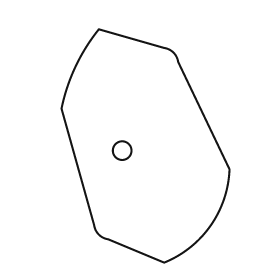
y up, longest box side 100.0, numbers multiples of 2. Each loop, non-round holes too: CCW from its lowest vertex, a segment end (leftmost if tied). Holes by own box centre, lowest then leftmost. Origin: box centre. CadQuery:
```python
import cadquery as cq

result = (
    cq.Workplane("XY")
    .moveTo(8.0, -50.0)
    .threePointArc((28.0, -34.0), (36.0, -10.0))
    .lineTo(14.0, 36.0)
    .threePointArc((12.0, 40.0), (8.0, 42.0))
    .lineTo(-20.0, 50.0)
    .threePointArc((-30.0, 34.0), (-36.0, 16.0))
    .lineTo(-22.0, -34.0)
    .threePointArc((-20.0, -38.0), (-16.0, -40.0))
    .close()
    .moveTo(-10.0, -2.0)
    .circle(4.0)
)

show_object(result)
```